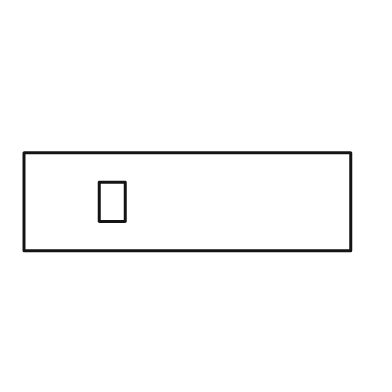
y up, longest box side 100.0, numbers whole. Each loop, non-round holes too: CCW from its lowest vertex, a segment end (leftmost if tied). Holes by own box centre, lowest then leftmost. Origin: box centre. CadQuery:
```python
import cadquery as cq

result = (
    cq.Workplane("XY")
    .moveTo(-50.0, -15.0)
    .lineTo(50.0, -15.0)
    .lineTo(50.0, 15.0)
    .lineTo(-50.0, 15.0)
    .close()
    .moveTo(-27.0, -6.0)
    .lineTo(-19.0, -6.0)
    .lineTo(-19.0, 6.0)
    .lineTo(-27.0, 6.0)
    .close()
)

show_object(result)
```